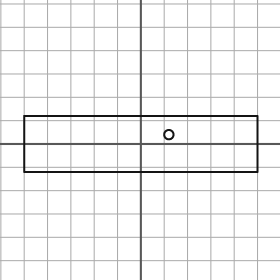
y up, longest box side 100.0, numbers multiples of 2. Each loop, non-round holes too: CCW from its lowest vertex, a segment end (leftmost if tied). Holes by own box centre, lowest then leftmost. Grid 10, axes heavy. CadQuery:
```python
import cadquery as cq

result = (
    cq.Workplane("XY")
    .moveTo(-50.0, -12.0)
    .lineTo(50.0, -12.0)
    .lineTo(50.0, 12.0)
    .lineTo(-50.0, 12.0)
    .close()
    .moveTo(12.0, 4.0)
    .circle(2.0)
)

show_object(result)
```